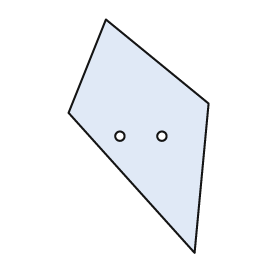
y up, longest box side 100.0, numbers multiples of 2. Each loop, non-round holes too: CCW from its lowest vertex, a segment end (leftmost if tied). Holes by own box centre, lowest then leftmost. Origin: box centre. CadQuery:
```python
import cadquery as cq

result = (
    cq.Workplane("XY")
    .moveTo(24.0, -50.0)
    .lineTo(30.0, 14.0)
    .lineTo(-14.0, 50.0)
    .lineTo(-30.0, 10.0)
    .close()
    .moveTo(-8.0, 0.0)
    .circle(2.0)
    .moveTo(10.0, 0.0)
    .circle(2.0)
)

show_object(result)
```